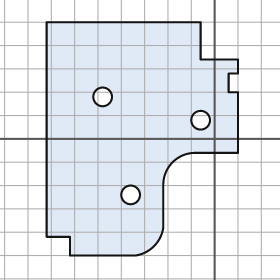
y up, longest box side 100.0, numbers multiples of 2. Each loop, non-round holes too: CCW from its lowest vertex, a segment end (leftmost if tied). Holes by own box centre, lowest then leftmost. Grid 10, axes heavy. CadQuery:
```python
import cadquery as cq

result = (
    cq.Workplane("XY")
    .moveTo(-62.0, -50.0)
    .lineTo(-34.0, -50.0)
    .threePointArc((-26.0, -46.0), (-22.0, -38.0))
    .lineTo(-22.0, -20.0)
    .threePointArc((-18.0, -10.0), (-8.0, -6.0))
    .lineTo(10.0, -6.0)
    .lineTo(10.0, 20.0)
    .lineTo(6.0, 20.0)
    .lineTo(6.0, 28.0)
    .lineTo(10.0, 28.0)
    .lineTo(10.0, 34.0)
    .lineTo(-6.0, 34.0)
    .lineTo(-6.0, 50.0)
    .lineTo(-72.0, 50.0)
    .lineTo(-72.0, -42.0)
    .lineTo(-62.0, -42.0)
    .close()
    .moveTo(-36.0, -24.0)
    .circle(4.0)
    .moveTo(-6.0, 8.0)
    .circle(4.0)
    .moveTo(-48.0, 18.0)
    .circle(4.0)
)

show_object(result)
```